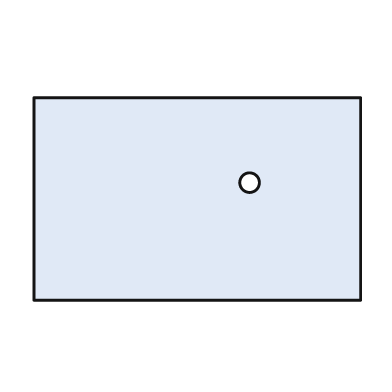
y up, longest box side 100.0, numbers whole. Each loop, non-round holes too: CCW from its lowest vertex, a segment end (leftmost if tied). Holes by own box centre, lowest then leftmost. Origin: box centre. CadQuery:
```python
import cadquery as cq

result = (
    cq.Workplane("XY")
    .moveTo(-50.0, -31.0)
    .lineTo(50.0, -31.0)
    .lineTo(50.0, 31.0)
    .lineTo(-50.0, 31.0)
    .close()
    .moveTo(16.0, 5.0)
    .circle(3.0)
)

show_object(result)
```